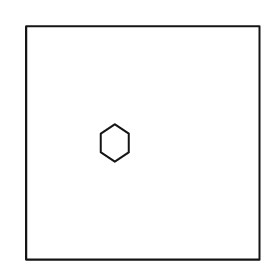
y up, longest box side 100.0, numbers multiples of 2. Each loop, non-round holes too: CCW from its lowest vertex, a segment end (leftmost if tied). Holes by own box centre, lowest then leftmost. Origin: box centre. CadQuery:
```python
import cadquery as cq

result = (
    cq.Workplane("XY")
    .moveTo(-50.0, -50.0)
    .lineTo(50.0, -50.0)
    .lineTo(50.0, 50.0)
    .lineTo(-50.0, 50.0)
    .close()
    .moveTo(-12.0, -8.0)
    .lineTo(-6.0, -4.0)
    .lineTo(-6.0, 4.0)
    .lineTo(-12.0, 8.0)
    .lineTo(-18.0, 4.0)
    .lineTo(-18.0, -4.0)
    .close()
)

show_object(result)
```